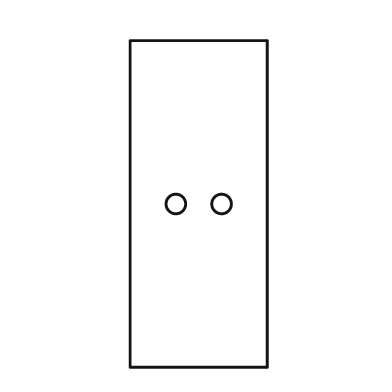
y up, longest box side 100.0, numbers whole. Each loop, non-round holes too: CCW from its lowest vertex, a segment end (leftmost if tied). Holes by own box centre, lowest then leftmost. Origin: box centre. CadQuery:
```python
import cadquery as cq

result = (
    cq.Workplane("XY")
    .moveTo(-21.0, -50.0)
    .lineTo(21.0, -50.0)
    .lineTo(21.0, 50.0)
    .lineTo(-21.0, 50.0)
    .close()
    .moveTo(-7.0, 0.0)
    .circle(3.0)
    .moveTo(7.0, 0.0)
    .circle(3.0)
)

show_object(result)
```